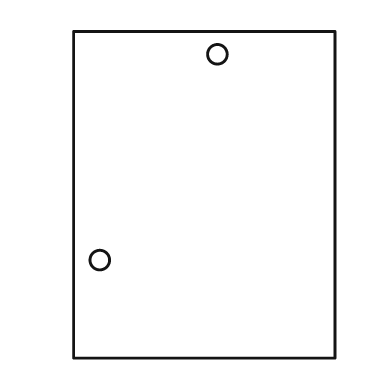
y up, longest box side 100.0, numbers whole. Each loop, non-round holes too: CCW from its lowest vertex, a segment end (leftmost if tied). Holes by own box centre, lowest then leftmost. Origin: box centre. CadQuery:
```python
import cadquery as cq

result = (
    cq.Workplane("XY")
    .moveTo(-40.0, -50.0)
    .lineTo(40.0, -50.0)
    .lineTo(40.0, 50.0)
    .lineTo(-40.0, 50.0)
    .close()
    .moveTo(-32.0, -20.0)
    .circle(3.0)
    .moveTo(4.0, 43.0)
    .circle(3.0)
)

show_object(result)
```